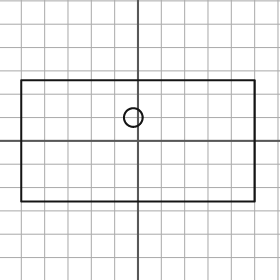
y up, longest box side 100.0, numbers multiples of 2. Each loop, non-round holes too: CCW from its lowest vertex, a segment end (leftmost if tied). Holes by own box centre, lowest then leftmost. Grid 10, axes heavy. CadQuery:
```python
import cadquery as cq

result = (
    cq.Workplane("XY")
    .moveTo(-50.0, -26.0)
    .lineTo(50.0, -26.0)
    .lineTo(50.0, 26.0)
    .lineTo(-50.0, 26.0)
    .close()
    .moveTo(-2.0, 10.0)
    .circle(4.0)
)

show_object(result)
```